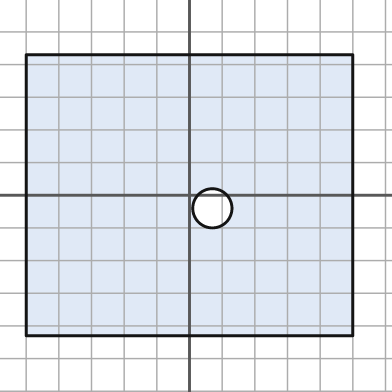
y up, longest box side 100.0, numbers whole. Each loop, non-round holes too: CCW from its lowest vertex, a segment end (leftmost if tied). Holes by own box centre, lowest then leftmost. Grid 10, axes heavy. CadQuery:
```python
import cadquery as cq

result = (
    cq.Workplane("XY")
    .moveTo(-50.0, -43.0)
    .lineTo(50.0, -43.0)
    .lineTo(50.0, 43.0)
    .lineTo(-50.0, 43.0)
    .close()
    .moveTo(7.0, -4.0)
    .circle(6.0)
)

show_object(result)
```